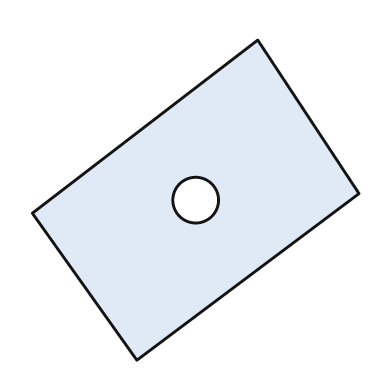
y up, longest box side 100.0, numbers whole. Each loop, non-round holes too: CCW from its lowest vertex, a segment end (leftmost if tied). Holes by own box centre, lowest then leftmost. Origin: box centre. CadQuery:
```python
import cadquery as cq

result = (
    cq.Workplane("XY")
    .moveTo(-18.0, -49.0)
    .lineTo(50.0, 2.0)
    .lineTo(19.0, 49.0)
    .lineTo(-50.0, -4.0)
    .close()
    .moveTo(0.0, 0.0)
    .circle(7.0)
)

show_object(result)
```